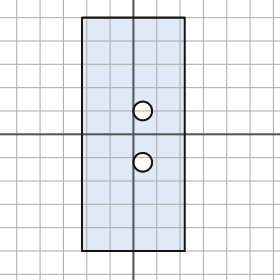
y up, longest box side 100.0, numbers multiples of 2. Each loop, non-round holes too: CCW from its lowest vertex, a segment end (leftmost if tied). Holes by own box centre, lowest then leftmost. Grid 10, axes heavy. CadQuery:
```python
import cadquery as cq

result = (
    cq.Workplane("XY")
    .moveTo(-22.0, -50.0)
    .lineTo(22.0, -50.0)
    .lineTo(22.0, 50.0)
    .lineTo(-22.0, 50.0)
    .close()
    .moveTo(4.0, -12.0)
    .circle(4.0)
    .moveTo(4.0, 10.0)
    .circle(4.0)
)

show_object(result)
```